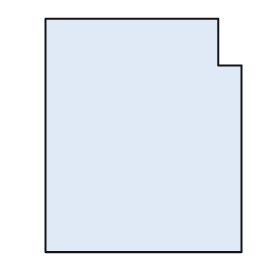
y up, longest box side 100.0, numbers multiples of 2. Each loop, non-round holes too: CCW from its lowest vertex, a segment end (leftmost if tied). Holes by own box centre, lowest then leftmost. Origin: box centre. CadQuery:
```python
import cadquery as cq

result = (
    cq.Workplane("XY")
    .moveTo(-42.0, -50.0)
    .lineTo(42.0, -50.0)
    .lineTo(42.0, 30.0)
    .lineTo(32.0, 30.0)
    .lineTo(32.0, 50.0)
    .lineTo(-42.0, 50.0)
    .close()
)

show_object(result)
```